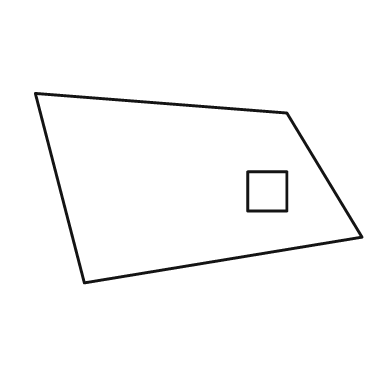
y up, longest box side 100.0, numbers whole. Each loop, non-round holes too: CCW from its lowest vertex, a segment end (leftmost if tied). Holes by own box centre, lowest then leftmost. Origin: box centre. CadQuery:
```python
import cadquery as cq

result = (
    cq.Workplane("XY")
    .moveTo(-35.0, -29.0)
    .lineTo(50.0, -15.0)
    .lineTo(27.0, 23.0)
    .lineTo(-50.0, 29.0)
    .close()
    .moveTo(15.0, -7.0)
    .lineTo(27.0, -7.0)
    .lineTo(27.0, 5.0)
    .lineTo(15.0, 5.0)
    .close()
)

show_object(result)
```